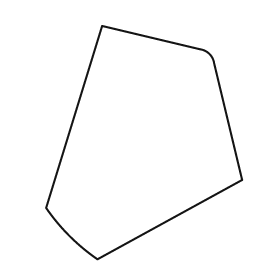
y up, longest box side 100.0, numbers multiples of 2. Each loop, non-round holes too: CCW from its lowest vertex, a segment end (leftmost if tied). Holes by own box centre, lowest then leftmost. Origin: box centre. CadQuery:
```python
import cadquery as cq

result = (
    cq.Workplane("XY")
    .moveTo(-20.0, -50.0)
    .lineTo(42.0, -16.0)
    .lineTo(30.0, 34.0)
    .threePointArc((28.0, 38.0), (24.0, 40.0))
    .lineTo(-18.0, 50.0)
    .lineTo(-42.0, -28.0)
    .threePointArc((-32.0, -40.0), (-20.0, -50.0))
    .close()
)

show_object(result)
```